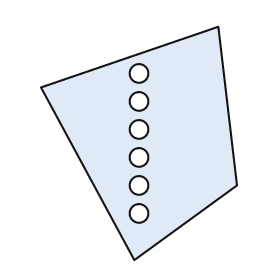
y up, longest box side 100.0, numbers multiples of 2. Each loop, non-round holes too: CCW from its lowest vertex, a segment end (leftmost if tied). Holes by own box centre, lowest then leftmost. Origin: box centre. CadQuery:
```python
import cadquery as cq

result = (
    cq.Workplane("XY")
    .moveTo(-2.0, -50.0)
    .lineTo(42.0, -18.0)
    .lineTo(34.0, 50.0)
    .lineTo(-42.0, 24.0)
    .close()
    .moveTo(0.0, -30.0)
    .circle(4.0)
    .moveTo(0.0, -18.0)
    .circle(4.0)
    .moveTo(0.0, -6.0)
    .circle(4.0)
    .moveTo(0.0, 6.0)
    .circle(4.0)
    .moveTo(0.0, 18.0)
    .circle(4.0)
    .moveTo(0.0, 30.0)
    .circle(4.0)
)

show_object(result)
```